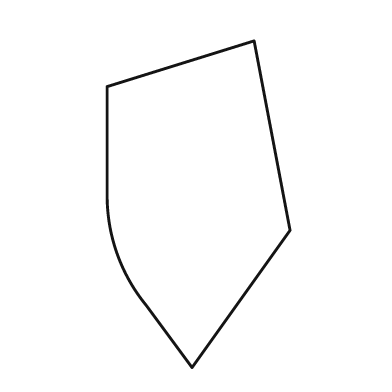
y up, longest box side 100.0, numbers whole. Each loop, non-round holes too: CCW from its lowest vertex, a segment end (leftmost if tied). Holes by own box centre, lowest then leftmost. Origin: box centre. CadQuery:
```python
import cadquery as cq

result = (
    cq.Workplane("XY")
    .moveTo(-2.0, -50.0)
    .lineTo(28.0, -8.0)
    .lineTo(17.0, 50.0)
    .lineTo(-28.0, 36.0)
    .lineTo(-28.0, 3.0)
    .threePointArc((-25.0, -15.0), (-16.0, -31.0))
    .close()
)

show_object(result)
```